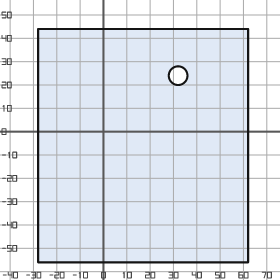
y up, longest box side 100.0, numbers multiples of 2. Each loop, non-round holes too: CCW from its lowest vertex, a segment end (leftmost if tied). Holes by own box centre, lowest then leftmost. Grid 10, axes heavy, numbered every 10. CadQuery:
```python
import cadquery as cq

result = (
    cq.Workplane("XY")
    .moveTo(-28.0, -56.0)
    .lineTo(62.0, -56.0)
    .lineTo(62.0, 44.0)
    .lineTo(-28.0, 44.0)
    .close()
    .moveTo(32.0, 24.0)
    .circle(4.0)
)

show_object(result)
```